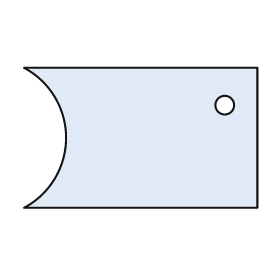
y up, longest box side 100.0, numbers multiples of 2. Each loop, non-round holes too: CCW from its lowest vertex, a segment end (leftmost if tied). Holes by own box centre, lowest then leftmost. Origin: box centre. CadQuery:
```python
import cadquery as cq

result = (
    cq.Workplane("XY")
    .moveTo(-50.0, -30.0)
    .lineTo(50.0, -30.0)
    .lineTo(50.0, 30.0)
    .lineTo(-50.0, 30.0)
    .threePointArc((-32.0, 0.0), (-50.0, -30.0))
    .close()
    .moveTo(36.0, 14.0)
    .circle(4.0)
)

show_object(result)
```